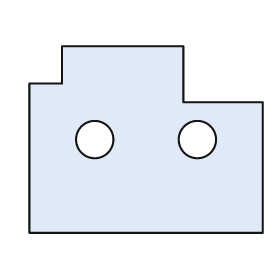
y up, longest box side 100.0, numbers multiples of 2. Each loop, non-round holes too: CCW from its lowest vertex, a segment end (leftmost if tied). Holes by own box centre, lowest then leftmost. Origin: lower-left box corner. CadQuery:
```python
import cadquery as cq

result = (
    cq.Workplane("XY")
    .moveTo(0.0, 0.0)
    .lineTo(100.0, 0.0)
    .lineTo(100.0, 56.0)
    .lineTo(66.0, 56.0)
    .lineTo(66.0, 80.0)
    .lineTo(14.0, 80.0)
    .lineTo(14.0, 64.0)
    .lineTo(0.0, 64.0)
    .close()
    .moveTo(28.0, 40.0)
    .circle(8.0)
    .moveTo(72.0, 40.0)
    .circle(8.0)
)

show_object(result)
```